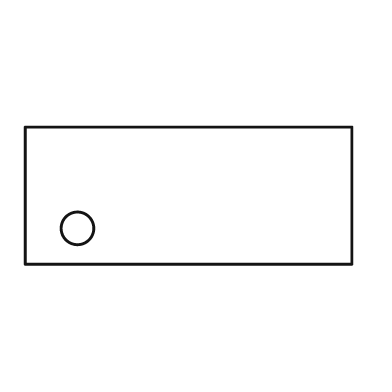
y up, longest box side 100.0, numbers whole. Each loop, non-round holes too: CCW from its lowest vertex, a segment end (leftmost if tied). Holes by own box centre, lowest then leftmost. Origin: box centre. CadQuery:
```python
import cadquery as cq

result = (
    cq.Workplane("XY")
    .moveTo(-50.0, -21.0)
    .lineTo(50.0, -21.0)
    .lineTo(50.0, 21.0)
    .lineTo(-50.0, 21.0)
    .close()
    .moveTo(-34.0, -10.0)
    .circle(5.0)
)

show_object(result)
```